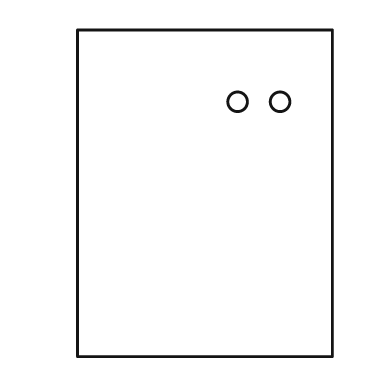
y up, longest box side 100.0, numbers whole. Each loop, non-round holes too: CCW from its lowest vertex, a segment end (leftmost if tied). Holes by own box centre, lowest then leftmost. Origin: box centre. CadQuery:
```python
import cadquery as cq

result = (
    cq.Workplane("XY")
    .moveTo(-39.0, -50.0)
    .lineTo(39.0, -50.0)
    .lineTo(39.0, 50.0)
    .lineTo(-39.0, 50.0)
    .close()
    .moveTo(10.0, 28.0)
    .circle(3.0)
    .moveTo(23.0, 28.0)
    .circle(3.0)
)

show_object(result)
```